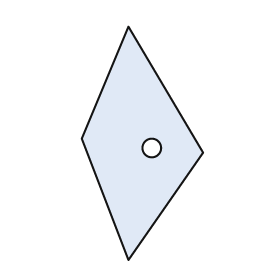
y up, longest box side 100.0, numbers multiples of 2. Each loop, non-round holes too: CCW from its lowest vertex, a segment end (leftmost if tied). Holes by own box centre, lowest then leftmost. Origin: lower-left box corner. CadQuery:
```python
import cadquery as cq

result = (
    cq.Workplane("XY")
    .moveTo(20.0, 0.0)
    .lineTo(52.0, 46.0)
    .lineTo(20.0, 100.0)
    .lineTo(0.0, 52.0)
    .close()
    .moveTo(30.0, 48.0)
    .circle(4.0)
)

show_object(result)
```